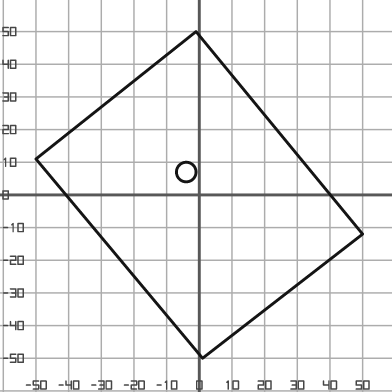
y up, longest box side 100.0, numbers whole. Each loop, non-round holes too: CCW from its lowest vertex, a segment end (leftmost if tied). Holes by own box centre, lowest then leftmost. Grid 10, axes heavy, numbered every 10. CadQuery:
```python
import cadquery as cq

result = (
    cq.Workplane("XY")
    .moveTo(1.0, -50.0)
    .lineTo(50.0, -12.0)
    .lineTo(-1.0, 50.0)
    .lineTo(-50.0, 11.0)
    .close()
    .moveTo(-4.0, 7.0)
    .circle(3.0)
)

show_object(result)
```